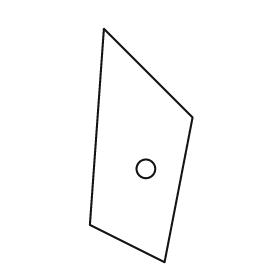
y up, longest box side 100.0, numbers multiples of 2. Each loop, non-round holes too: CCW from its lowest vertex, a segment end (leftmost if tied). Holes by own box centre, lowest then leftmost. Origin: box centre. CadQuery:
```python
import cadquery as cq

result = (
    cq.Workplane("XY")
    .moveTo(10.0, -50.0)
    .lineTo(22.0, 12.0)
    .lineTo(-16.0, 50.0)
    .lineTo(-22.0, -34.0)
    .close()
    .moveTo(2.0, -10.0)
    .circle(4.0)
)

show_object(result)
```